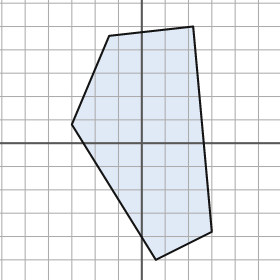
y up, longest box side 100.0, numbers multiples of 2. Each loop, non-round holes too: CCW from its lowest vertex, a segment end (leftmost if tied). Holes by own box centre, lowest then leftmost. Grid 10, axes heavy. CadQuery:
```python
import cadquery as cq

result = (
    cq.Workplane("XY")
    .moveTo(6.0, -50.0)
    .lineTo(30.0, -38.0)
    .lineTo(22.0, 50.0)
    .lineTo(-14.0, 46.0)
    .lineTo(-30.0, 8.0)
    .close()
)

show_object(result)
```